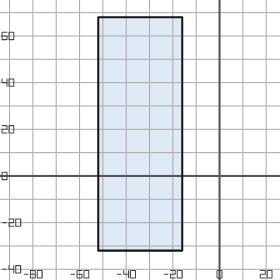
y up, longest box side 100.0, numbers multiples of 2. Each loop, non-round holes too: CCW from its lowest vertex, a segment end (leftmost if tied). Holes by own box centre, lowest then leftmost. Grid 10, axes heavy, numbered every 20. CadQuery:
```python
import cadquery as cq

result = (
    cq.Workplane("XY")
    .moveTo(-52.0, -32.0)
    .lineTo(-16.0, -32.0)
    .lineTo(-16.0, 68.0)
    .lineTo(-52.0, 68.0)
    .close()
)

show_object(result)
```